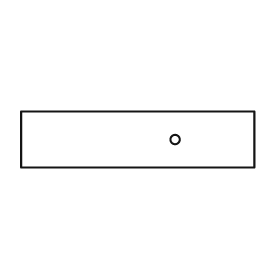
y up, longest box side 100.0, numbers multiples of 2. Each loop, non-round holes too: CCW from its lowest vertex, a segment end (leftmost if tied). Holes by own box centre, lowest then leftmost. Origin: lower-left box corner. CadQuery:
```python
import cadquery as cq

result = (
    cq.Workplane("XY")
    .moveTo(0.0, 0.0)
    .lineTo(100.0, 0.0)
    .lineTo(100.0, 24.0)
    .lineTo(0.0, 24.0)
    .close()
    .moveTo(66.0, 12.0)
    .circle(2.0)
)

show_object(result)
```